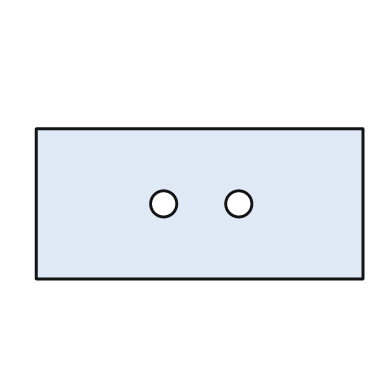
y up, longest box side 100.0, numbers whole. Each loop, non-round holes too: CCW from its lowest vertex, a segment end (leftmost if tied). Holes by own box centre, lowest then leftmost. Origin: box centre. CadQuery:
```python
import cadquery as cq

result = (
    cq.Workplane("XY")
    .moveTo(-50.0, -23.0)
    .lineTo(50.0, -23.0)
    .lineTo(50.0, 23.0)
    .lineTo(-50.0, 23.0)
    .close()
    .moveTo(-11.0, 0.0)
    .circle(4.0)
    .moveTo(12.0, 0.0)
    .circle(4.0)
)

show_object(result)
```